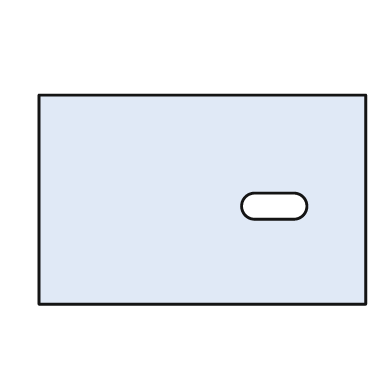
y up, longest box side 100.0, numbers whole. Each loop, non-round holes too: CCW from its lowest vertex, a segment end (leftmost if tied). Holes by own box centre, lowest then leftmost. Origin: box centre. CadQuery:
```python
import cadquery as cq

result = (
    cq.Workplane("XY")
    .moveTo(-50.0, -32.0)
    .lineTo(50.0, -32.0)
    .lineTo(50.0, 32.0)
    .lineTo(-50.0, 32.0)
    .close()
    .moveTo(16.0, -6.0)
    .lineTo(28.0, -6.0)
    .threePointArc((32.0, -2.0), (28.0, 2.0))
    .lineTo(16.0, 2.0)
    .threePointArc((12.0, -2.0), (16.0, -6.0))
    .close()
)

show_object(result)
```